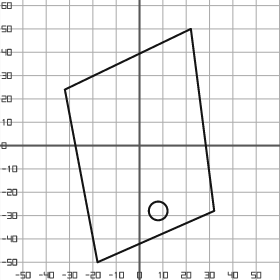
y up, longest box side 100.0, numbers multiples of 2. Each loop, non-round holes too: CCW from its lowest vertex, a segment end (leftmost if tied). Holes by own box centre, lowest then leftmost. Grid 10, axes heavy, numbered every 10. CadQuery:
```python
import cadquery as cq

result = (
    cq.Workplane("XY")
    .moveTo(-18.0, -50.0)
    .lineTo(32.0, -28.0)
    .lineTo(22.0, 50.0)
    .lineTo(-32.0, 24.0)
    .close()
    .moveTo(8.0, -28.0)
    .circle(4.0)
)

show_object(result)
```